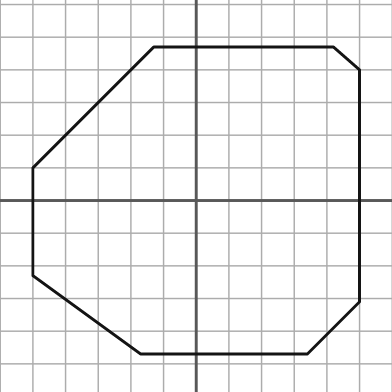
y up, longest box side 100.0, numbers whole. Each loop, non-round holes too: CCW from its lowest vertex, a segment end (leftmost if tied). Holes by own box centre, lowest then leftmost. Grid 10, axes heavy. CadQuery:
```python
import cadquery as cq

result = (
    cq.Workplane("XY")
    .moveTo(-17.0, -47.0)
    .lineTo(34.0, -47.0)
    .lineTo(50.0, -31.0)
    .lineTo(50.0, 40.0)
    .lineTo(42.0, 47.0)
    .lineTo(-13.0, 47.0)
    .lineTo(-50.0, 10.0)
    .lineTo(-50.0, -23.0)
    .close()
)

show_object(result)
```